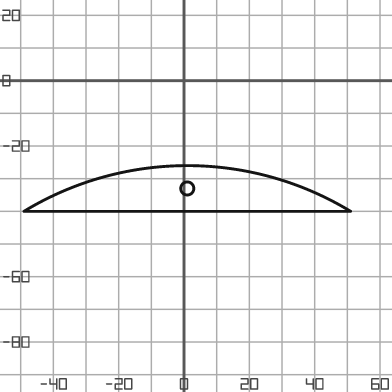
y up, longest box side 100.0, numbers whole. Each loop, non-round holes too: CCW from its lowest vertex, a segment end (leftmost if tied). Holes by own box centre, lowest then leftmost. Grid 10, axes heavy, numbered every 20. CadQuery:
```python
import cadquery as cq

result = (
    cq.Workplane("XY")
    .moveTo(-49.0, -40.0)
    .lineTo(51.0, -40.0)
    .threePointArc((1.0, -26.0), (-49.0, -40.0))
    .close()
    .moveTo(1.0, -33.0)
    .circle(2.0)
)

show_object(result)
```